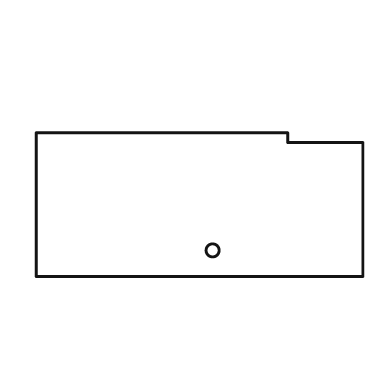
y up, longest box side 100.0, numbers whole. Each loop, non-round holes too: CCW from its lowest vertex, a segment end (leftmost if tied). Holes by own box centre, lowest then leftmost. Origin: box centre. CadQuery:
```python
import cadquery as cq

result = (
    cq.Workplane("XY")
    .moveTo(-50.0, -22.0)
    .lineTo(50.0, -22.0)
    .lineTo(50.0, 19.0)
    .lineTo(27.0, 19.0)
    .lineTo(27.0, 22.0)
    .lineTo(-50.0, 22.0)
    .close()
    .moveTo(4.0, -14.0)
    .circle(2.0)
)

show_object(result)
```